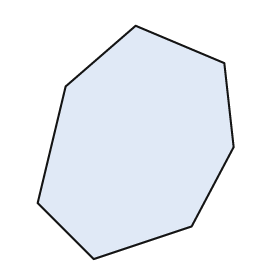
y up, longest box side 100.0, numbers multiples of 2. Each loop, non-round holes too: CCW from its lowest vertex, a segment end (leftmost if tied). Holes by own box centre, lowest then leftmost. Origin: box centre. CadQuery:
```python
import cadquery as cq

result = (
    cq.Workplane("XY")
    .moveTo(-18.0, -50.0)
    .lineTo(24.0, -36.0)
    .lineTo(42.0, -2.0)
    .lineTo(38.0, 34.0)
    .lineTo(0.0, 50.0)
    .lineTo(-30.0, 24.0)
    .lineTo(-42.0, -26.0)
    .close()
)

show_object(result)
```